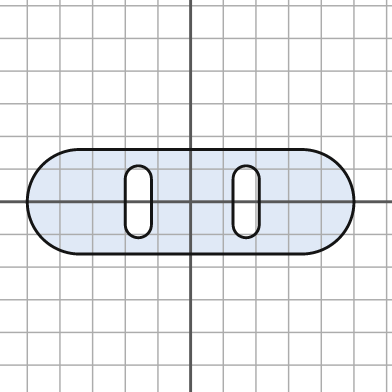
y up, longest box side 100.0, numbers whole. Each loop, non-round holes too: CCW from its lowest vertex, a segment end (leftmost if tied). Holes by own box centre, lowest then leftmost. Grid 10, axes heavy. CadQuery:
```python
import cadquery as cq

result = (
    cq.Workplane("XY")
    .moveTo(-34.0, -16.0)
    .lineTo(34.0, -16.0)
    .threePointArc((50.0, 0.0), (34.0, 16.0))
    .lineTo(-34.0, 16.0)
    .threePointArc((-50.0, 0.0), (-34.0, -16.0))
    .close()
    .moveTo(-20.0, -7.0)
    .threePointArc((-16.0, -11.0), (-12.0, -7.0))
    .lineTo(-12.0, 7.0)
    .threePointArc((-16.0, 11.0), (-20.0, 7.0))
    .close()
    .moveTo(13.0, -7.0)
    .threePointArc((17.0, -11.0), (21.0, -7.0))
    .lineTo(21.0, 7.0)
    .threePointArc((17.0, 11.0), (13.0, 7.0))
    .close()
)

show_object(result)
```